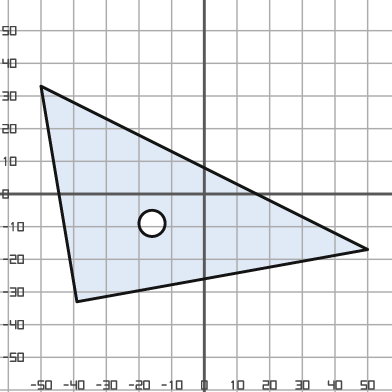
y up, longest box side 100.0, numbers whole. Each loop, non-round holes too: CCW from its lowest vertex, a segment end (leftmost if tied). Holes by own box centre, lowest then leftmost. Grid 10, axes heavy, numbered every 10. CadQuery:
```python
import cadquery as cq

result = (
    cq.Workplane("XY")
    .moveTo(-39.0, -33.0)
    .lineTo(50.0, -17.0)
    .lineTo(-50.0, 33.0)
    .close()
    .moveTo(-16.0, -9.0)
    .circle(4.0)
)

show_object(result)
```